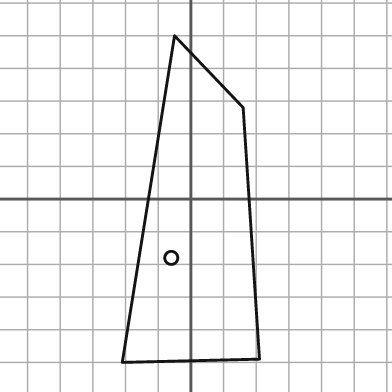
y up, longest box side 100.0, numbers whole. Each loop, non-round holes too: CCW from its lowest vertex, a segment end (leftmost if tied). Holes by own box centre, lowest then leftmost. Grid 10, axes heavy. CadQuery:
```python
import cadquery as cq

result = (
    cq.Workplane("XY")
    .moveTo(-21.0, -50.0)
    .lineTo(21.0, -49.0)
    .lineTo(16.0, 28.0)
    .lineTo(-5.0, 50.0)
    .close()
    .moveTo(-6.0, -18.0)
    .circle(2.0)
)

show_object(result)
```